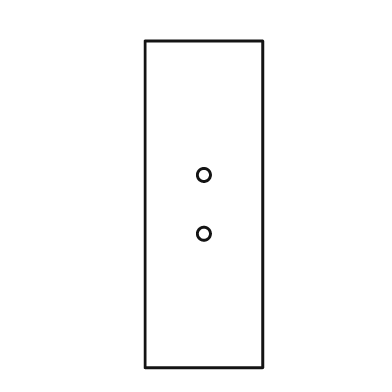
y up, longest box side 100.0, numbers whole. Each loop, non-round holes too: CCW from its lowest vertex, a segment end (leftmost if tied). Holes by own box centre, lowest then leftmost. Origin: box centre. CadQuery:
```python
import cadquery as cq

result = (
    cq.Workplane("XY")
    .moveTo(-18.0, -50.0)
    .lineTo(18.0, -50.0)
    .lineTo(18.0, 50.0)
    .lineTo(-18.0, 50.0)
    .close()
    .moveTo(0.0, -9.0)
    .circle(2.0)
    .moveTo(0.0, 9.0)
    .circle(2.0)
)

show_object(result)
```